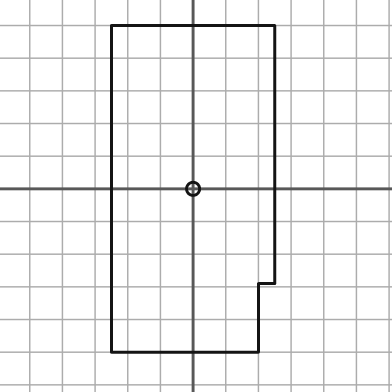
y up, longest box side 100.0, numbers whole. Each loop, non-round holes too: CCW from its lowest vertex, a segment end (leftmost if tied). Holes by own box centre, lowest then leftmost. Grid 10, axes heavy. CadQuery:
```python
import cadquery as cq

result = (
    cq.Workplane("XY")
    .moveTo(-25.0, -50.0)
    .lineTo(20.0, -50.0)
    .lineTo(20.0, -29.0)
    .lineTo(25.0, -29.0)
    .lineTo(25.0, 50.0)
    .lineTo(-25.0, 50.0)
    .close()
    .moveTo(0.0, 0.0)
    .circle(2.0)
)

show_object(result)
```